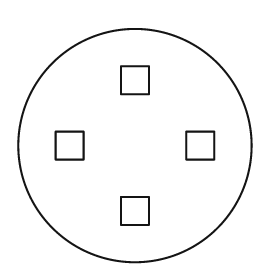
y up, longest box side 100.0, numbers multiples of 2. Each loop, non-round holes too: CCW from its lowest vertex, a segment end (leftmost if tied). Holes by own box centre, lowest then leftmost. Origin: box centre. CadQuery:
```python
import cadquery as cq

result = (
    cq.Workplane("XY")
    .moveTo(0.0, 0.0)
    .circle(50.0)
    .moveTo(-6.0, -34.0)
    .lineTo(6.0, -34.0)
    .lineTo(6.0, -22.0)
    .lineTo(-6.0, -22.0)
    .close()
    .moveTo(-34.0, -6.0)
    .lineTo(-22.0, -6.0)
    .lineTo(-22.0, 6.0)
    .lineTo(-34.0, 6.0)
    .close()
    .moveTo(22.0, -6.0)
    .lineTo(34.0, -6.0)
    .lineTo(34.0, 6.0)
    .lineTo(22.0, 6.0)
    .close()
    .moveTo(-6.0, 22.0)
    .lineTo(6.0, 22.0)
    .lineTo(6.0, 34.0)
    .lineTo(-6.0, 34.0)
    .close()
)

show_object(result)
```